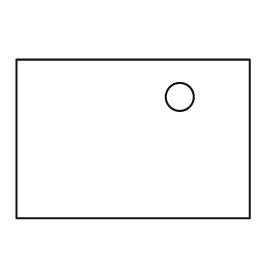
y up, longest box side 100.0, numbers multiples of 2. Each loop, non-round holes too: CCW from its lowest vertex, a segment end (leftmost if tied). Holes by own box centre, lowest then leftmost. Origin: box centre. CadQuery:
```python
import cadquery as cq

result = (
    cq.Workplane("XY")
    .moveTo(-50.0, -34.0)
    .lineTo(50.0, -34.0)
    .lineTo(50.0, 34.0)
    .lineTo(-50.0, 34.0)
    .close()
    .moveTo(20.0, 18.0)
    .circle(6.0)
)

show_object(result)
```